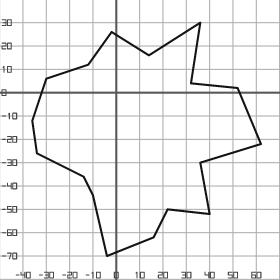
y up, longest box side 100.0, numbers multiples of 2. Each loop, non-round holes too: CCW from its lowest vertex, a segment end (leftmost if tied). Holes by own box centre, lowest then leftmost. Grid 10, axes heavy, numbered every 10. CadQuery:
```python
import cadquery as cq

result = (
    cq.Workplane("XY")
    .moveTo(-4.0, -70.0)
    .lineTo(16.0, -62.0)
    .lineTo(22.0, -50.0)
    .lineTo(40.0, -52.0)
    .lineTo(36.0, -30.0)
    .lineTo(62.0, -22.0)
    .lineTo(52.0, 2.0)
    .lineTo(32.0, 4.0)
    .lineTo(36.0, 30.0)
    .lineTo(14.0, 16.0)
    .lineTo(-2.0, 26.0)
    .lineTo(-12.0, 12.0)
    .lineTo(-30.0, 6.0)
    .lineTo(-36.0, -12.0)
    .lineTo(-34.0, -26.0)
    .lineTo(-14.0, -36.0)
    .lineTo(-10.0, -44.0)
    .close()
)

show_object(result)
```